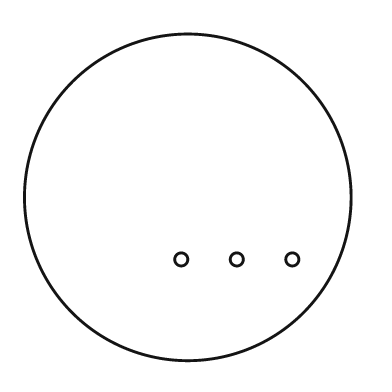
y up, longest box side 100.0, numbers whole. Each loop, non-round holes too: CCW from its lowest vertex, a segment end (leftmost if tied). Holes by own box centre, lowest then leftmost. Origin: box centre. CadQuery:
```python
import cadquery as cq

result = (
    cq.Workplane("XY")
    .moveTo(0.0, 0.0)
    .circle(50.0)
    .moveTo(-2.0, -19.0)
    .circle(2.0)
    .moveTo(15.0, -19.0)
    .circle(2.0)
    .moveTo(32.0, -19.0)
    .circle(2.0)
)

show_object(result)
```